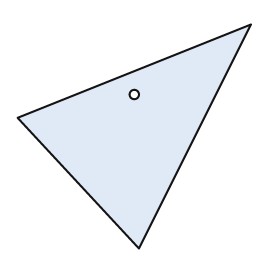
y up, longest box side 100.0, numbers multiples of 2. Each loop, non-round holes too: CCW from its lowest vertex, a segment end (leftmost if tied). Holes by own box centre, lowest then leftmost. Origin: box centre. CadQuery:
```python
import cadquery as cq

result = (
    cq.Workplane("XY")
    .moveTo(2.0, -48.0)
    .lineTo(50.0, 48.0)
    .lineTo(-50.0, 8.0)
    .close()
    .moveTo(0.0, 18.0)
    .circle(2.0)
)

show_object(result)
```